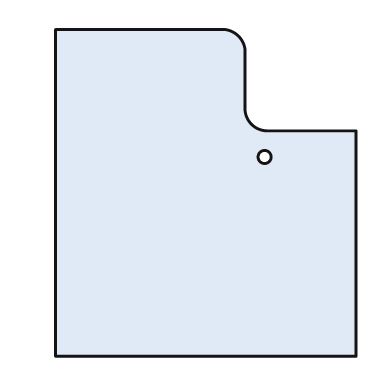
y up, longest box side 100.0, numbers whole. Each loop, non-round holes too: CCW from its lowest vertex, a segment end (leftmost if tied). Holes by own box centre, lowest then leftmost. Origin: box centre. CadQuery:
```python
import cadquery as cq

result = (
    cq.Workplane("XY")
    .moveTo(-46.0, -50.0)
    .lineTo(46.0, -50.0)
    .lineTo(46.0, 19.0)
    .lineTo(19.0, 19.0)
    .threePointArc((14.0, 21.0), (12.0, 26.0))
    .lineTo(12.0, 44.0)
    .threePointArc((10.0, 48.0), (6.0, 50.0))
    .lineTo(-46.0, 50.0)
    .close()
    .moveTo(18.0, 11.0)
    .circle(2.0)
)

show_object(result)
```